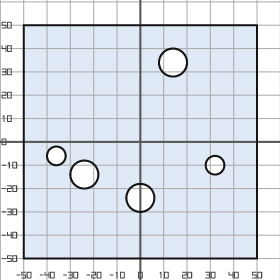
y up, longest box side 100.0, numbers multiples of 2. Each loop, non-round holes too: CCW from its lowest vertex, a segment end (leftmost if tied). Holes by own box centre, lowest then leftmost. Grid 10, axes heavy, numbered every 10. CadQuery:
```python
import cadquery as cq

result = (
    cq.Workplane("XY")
    .moveTo(-50.0, -50.0)
    .lineTo(50.0, -50.0)
    .lineTo(50.0, 50.0)
    .lineTo(-50.0, 50.0)
    .close()
    .moveTo(0.0, -24.0)
    .circle(6.0)
    .moveTo(-24.0, -14.0)
    .circle(6.0)
    .moveTo(32.0, -10.0)
    .circle(4.0)
    .moveTo(-36.0, -6.0)
    .circle(4.0)
    .moveTo(14.0, 34.0)
    .circle(6.0)
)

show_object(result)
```